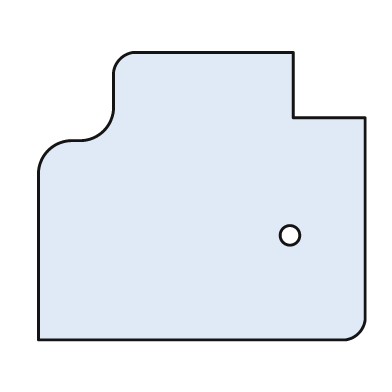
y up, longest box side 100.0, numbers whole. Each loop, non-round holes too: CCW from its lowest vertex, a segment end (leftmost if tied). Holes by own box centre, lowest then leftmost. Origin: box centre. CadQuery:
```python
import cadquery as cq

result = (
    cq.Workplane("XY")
    .moveTo(-50.0, -44.0)
    .lineTo(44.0, -44.0)
    .threePointArc((48.0, -42.0), (50.0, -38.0))
    .lineTo(50.0, 24.0)
    .lineTo(28.0, 24.0)
    .lineTo(28.0, 44.0)
    .lineTo(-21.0, 44.0)
    .threePointArc((-25.0, 42.0), (-27.0, 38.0))
    .lineTo(-27.0, 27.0)
    .threePointArc((-30.0, 20.0), (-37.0, 17.0))
    .lineTo(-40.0, 17.0)
    .threePointArc((-47.0, 14.0), (-50.0, 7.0))
    .close()
    .moveTo(27.0, -12.0)
    .circle(3.0)
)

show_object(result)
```